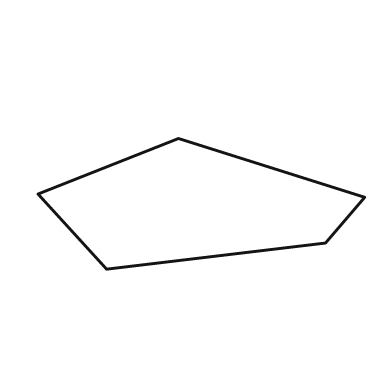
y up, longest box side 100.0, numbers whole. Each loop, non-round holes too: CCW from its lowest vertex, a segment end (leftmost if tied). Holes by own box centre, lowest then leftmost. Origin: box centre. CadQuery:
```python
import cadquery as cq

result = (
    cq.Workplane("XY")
    .moveTo(-29.0, -20.0)
    .lineTo(38.0, -12.0)
    .lineTo(50.0, 2.0)
    .lineTo(-7.0, 20.0)
    .lineTo(-50.0, 3.0)
    .close()
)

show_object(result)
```